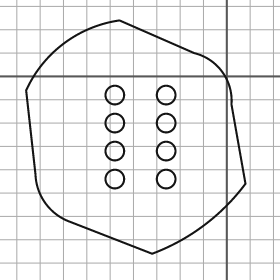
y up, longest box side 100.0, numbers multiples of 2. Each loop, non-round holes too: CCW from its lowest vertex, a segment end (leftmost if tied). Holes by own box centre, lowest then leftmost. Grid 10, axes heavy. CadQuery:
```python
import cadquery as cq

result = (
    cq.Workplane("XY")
    .moveTo(-32.0, -76.0)
    .threePointArc((-10.0, -64.0), (8.0, -46.0))
    .lineTo(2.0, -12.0)
    .threePointArc((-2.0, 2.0), (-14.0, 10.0))
    .lineTo(-46.0, 24.0)
    .threePointArc((-70.0, 14.0), (-86.0, -6.0))
    .lineTo(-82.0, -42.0)
    .threePointArc((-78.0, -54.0), (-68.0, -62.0))
    .close()
    .moveTo(-48.0, -44.0)
    .circle(4.0)
    .moveTo(-26.0, -44.0)
    .circle(4.0)
    .moveTo(-48.0, -32.0)
    .circle(4.0)
    .moveTo(-26.0, -32.0)
    .circle(4.0)
    .moveTo(-48.0, -20.0)
    .circle(4.0)
    .moveTo(-26.0, -20.0)
    .circle(4.0)
    .moveTo(-48.0, -8.0)
    .circle(4.0)
    .moveTo(-26.0, -8.0)
    .circle(4.0)
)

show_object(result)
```